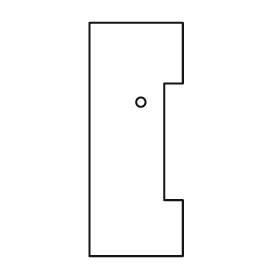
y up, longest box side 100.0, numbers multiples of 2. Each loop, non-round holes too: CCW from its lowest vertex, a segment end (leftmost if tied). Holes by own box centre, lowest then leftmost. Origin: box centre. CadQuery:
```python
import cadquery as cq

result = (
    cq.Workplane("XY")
    .moveTo(-20.0, -50.0)
    .lineTo(20.0, -50.0)
    .lineTo(20.0, -26.0)
    .lineTo(12.0, -26.0)
    .lineTo(12.0, 24.0)
    .lineTo(20.0, 24.0)
    .lineTo(20.0, 50.0)
    .lineTo(-20.0, 50.0)
    .close()
    .moveTo(2.0, 16.0)
    .circle(2.0)
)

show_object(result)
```